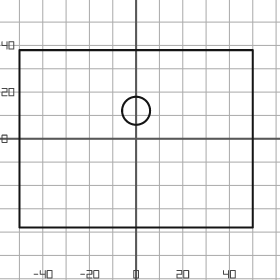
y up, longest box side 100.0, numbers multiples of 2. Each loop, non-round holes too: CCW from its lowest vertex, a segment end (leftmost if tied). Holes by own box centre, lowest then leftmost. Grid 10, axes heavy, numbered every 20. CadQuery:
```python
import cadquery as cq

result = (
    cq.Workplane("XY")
    .moveTo(-50.0, -38.0)
    .lineTo(50.0, -38.0)
    .lineTo(50.0, 38.0)
    .lineTo(-50.0, 38.0)
    .close()
    .moveTo(0.0, 12.0)
    .circle(6.0)
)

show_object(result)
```